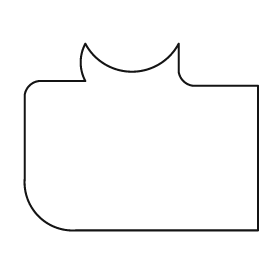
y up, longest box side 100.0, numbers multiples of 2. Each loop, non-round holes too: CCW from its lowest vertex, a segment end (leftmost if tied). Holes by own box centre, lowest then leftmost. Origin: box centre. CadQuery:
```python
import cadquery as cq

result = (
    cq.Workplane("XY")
    .moveTo(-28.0, -40.0)
    .lineTo(50.0, -40.0)
    .lineTo(50.0, 22.0)
    .lineTo(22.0, 22.0)
    .threePointArc((18.0, 24.0), (16.0, 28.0))
    .lineTo(16.0, 40.0)
    .threePointArc((-4.0, 28.0), (-24.0, 40.0))
    .threePointArc((-26.0, 32.0), (-24.0, 24.0))
    .lineTo(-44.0, 24.0)
    .threePointArc((-48.0, 22.0), (-50.0, 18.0))
    .lineTo(-50.0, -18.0)
    .threePointArc((-44.0, -34.0), (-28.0, -40.0))
    .close()
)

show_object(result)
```